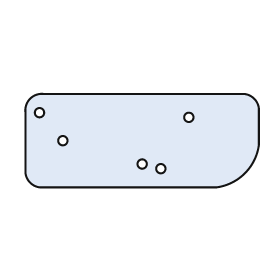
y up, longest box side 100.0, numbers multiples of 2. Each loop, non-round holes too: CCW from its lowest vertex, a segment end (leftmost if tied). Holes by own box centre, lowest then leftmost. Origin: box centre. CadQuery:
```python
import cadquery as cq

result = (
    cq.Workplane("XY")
    .moveTo(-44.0, -20.0)
    .lineTo(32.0, -20.0)
    .threePointArc((44.0, -14.0), (50.0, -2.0))
    .lineTo(50.0, 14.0)
    .threePointArc((48.0, 18.0), (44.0, 20.0))
    .lineTo(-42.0, 20.0)
    .threePointArc((-48.0, 18.0), (-50.0, 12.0))
    .lineTo(-50.0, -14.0)
    .threePointArc((-48.0, -18.0), (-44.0, -20.0))
    .close()
    .moveTo(8.0, -12.0)
    .circle(2.0)
    .moveTo(0.0, -10.0)
    .circle(2.0)
    .moveTo(-34.0, 0.0)
    .circle(2.0)
    .moveTo(20.0, 10.0)
    .circle(2.0)
    .moveTo(-44.0, 12.0)
    .circle(2.0)
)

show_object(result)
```